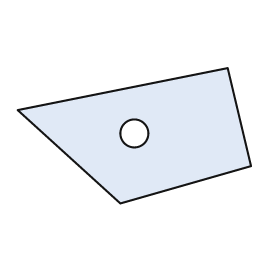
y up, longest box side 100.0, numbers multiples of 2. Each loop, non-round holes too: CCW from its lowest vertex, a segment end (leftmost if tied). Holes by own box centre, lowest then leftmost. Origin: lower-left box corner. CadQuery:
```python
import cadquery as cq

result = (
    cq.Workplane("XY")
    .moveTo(44.0, 0.0)
    .lineTo(100.0, 16.0)
    .lineTo(90.0, 58.0)
    .lineTo(0.0, 40.0)
    .close()
    .moveTo(50.0, 30.0)
    .circle(6.0)
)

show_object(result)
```